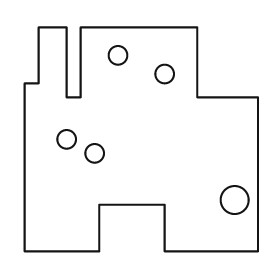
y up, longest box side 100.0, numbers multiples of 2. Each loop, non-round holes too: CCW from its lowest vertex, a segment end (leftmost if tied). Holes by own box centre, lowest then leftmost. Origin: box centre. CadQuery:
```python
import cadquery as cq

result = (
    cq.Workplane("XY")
    .moveTo(-50.0, -48.0)
    .lineTo(-18.0, -48.0)
    .lineTo(-18.0, -28.0)
    .lineTo(10.0, -28.0)
    .lineTo(10.0, -48.0)
    .lineTo(50.0, -48.0)
    .lineTo(50.0, 18.0)
    .lineTo(24.0, 18.0)
    .lineTo(24.0, 48.0)
    .lineTo(-26.0, 48.0)
    .lineTo(-26.0, 18.0)
    .lineTo(-32.0, 18.0)
    .lineTo(-32.0, 48.0)
    .lineTo(-44.0, 48.0)
    .lineTo(-44.0, 24.0)
    .lineTo(-50.0, 24.0)
    .close()
    .moveTo(40.0, -26.0)
    .circle(6.0)
    .moveTo(-20.0, -6.0)
    .circle(4.0)
    .moveTo(-32.0, 0.0)
    .circle(4.0)
    .moveTo(10.0, 28.0)
    .circle(4.0)
    .moveTo(-10.0, 36.0)
    .circle(4.0)
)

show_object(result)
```